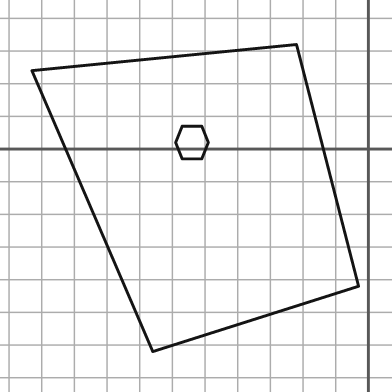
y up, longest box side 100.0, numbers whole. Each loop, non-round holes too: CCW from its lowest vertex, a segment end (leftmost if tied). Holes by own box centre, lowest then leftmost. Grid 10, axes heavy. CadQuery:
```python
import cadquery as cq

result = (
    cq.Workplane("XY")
    .moveTo(-66.0, -62.0)
    .lineTo(-3.0, -42.0)
    .lineTo(-22.0, 32.0)
    .lineTo(-103.0, 24.0)
    .close()
    .moveTo(-57.0, -3.0)
    .lineTo(-51.0, -3.0)
    .lineTo(-49.0, 2.0)
    .lineTo(-51.0, 7.0)
    .lineTo(-57.0, 7.0)
    .lineTo(-59.0, 2.0)
    .close()
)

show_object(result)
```